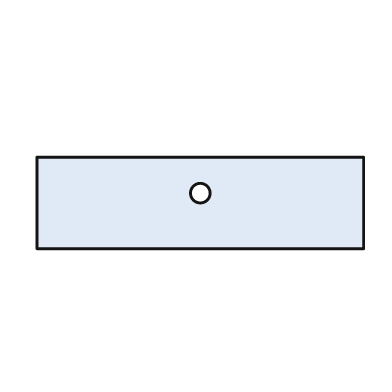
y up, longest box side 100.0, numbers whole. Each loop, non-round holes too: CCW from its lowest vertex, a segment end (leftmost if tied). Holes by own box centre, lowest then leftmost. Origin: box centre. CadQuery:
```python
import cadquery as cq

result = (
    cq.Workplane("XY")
    .moveTo(-50.0, -14.0)
    .lineTo(50.0, -14.0)
    .lineTo(50.0, 14.0)
    .lineTo(-50.0, 14.0)
    .close()
    .moveTo(0.0, 3.0)
    .circle(3.0)
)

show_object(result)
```